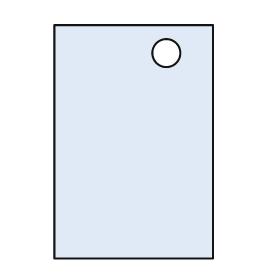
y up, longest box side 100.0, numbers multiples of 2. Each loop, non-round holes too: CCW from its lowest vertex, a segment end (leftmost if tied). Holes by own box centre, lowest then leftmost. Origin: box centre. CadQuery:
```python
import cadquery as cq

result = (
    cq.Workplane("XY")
    .moveTo(-34.0, -50.0)
    .lineTo(34.0, -50.0)
    .lineTo(34.0, 50.0)
    .lineTo(-34.0, 50.0)
    .close()
    .moveTo(14.0, 38.0)
    .circle(6.0)
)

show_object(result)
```